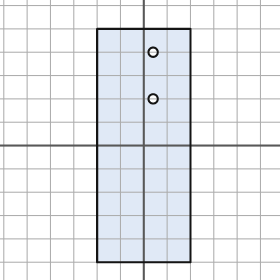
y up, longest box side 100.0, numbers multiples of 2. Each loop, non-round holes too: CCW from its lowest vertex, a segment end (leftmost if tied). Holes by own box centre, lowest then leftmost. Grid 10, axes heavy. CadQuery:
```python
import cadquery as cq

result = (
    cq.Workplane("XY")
    .moveTo(-20.0, -50.0)
    .lineTo(20.0, -50.0)
    .lineTo(20.0, 50.0)
    .lineTo(-20.0, 50.0)
    .close()
    .moveTo(4.0, 20.0)
    .circle(2.0)
    .moveTo(4.0, 40.0)
    .circle(2.0)
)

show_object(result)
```